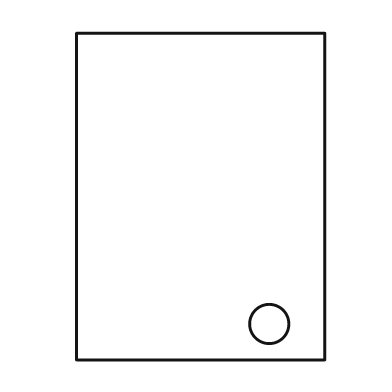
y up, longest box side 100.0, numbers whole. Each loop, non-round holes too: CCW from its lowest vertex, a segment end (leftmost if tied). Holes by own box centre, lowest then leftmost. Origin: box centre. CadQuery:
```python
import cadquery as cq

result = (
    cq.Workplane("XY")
    .moveTo(-38.0, -50.0)
    .lineTo(38.0, -50.0)
    .lineTo(38.0, 50.0)
    .lineTo(-38.0, 50.0)
    .close()
    .moveTo(21.0, -39.0)
    .circle(6.0)
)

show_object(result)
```